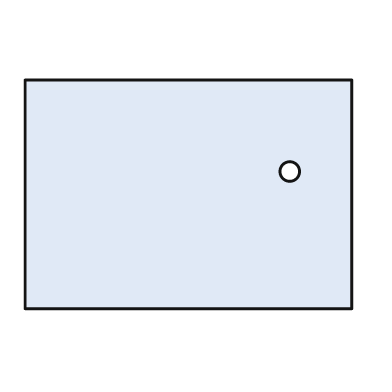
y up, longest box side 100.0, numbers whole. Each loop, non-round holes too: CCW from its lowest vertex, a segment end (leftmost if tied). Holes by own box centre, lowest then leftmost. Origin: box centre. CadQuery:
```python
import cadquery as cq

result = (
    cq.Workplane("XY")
    .moveTo(-50.0, -35.0)
    .lineTo(50.0, -35.0)
    .lineTo(50.0, 35.0)
    .lineTo(-50.0, 35.0)
    .close()
    .moveTo(31.0, 7.0)
    .circle(3.0)
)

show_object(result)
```